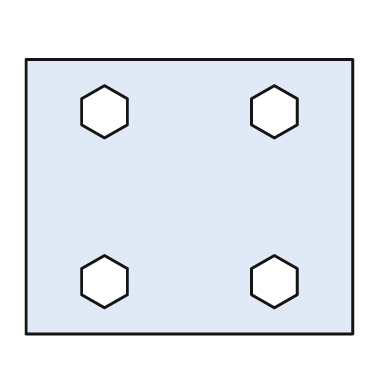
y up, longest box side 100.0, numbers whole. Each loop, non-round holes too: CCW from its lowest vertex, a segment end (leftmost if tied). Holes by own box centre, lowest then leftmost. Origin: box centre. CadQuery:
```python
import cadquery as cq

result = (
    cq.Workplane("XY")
    .moveTo(-50.0, -42.0)
    .lineTo(50.0, -42.0)
    .lineTo(50.0, 42.0)
    .lineTo(-50.0, 42.0)
    .close()
    .moveTo(-26.0, -34.0)
    .lineTo(-19.0, -30.0)
    .lineTo(-19.0, -22.0)
    .lineTo(-26.0, -18.0)
    .lineTo(-33.0, -22.0)
    .lineTo(-33.0, -30.0)
    .close()
    .moveTo(26.0, -34.0)
    .lineTo(33.0, -30.0)
    .lineTo(33.0, -22.0)
    .lineTo(26.0, -18.0)
    .lineTo(19.0, -22.0)
    .lineTo(19.0, -30.0)
    .close()
    .moveTo(-26.0, 18.0)
    .lineTo(-19.0, 22.0)
    .lineTo(-19.0, 30.0)
    .lineTo(-26.0, 34.0)
    .lineTo(-33.0, 30.0)
    .lineTo(-33.0, 22.0)
    .close()
    .moveTo(26.0, 18.0)
    .lineTo(33.0, 22.0)
    .lineTo(33.0, 30.0)
    .lineTo(26.0, 34.0)
    .lineTo(19.0, 30.0)
    .lineTo(19.0, 22.0)
    .close()
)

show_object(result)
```